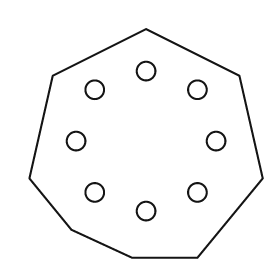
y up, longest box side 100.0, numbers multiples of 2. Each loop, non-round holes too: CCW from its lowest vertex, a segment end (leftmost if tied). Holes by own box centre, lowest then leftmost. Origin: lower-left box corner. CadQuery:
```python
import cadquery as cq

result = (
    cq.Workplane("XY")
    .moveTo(44.0, 0.0)
    .lineTo(72.0, 0.0)
    .lineTo(100.0, 34.0)
    .lineTo(90.0, 78.0)
    .lineTo(50.0, 98.0)
    .lineTo(10.0, 78.0)
    .lineTo(0.0, 34.0)
    .lineTo(18.0, 12.0)
    .close()
    .moveTo(50.0, 20.0)
    .circle(4.0)
    .moveTo(28.0, 28.0)
    .circle(4.0)
    .moveTo(72.0, 28.0)
    .circle(4.0)
    .moveTo(20.0, 50.0)
    .circle(4.0)
    .moveTo(80.0, 50.0)
    .circle(4.0)
    .moveTo(28.0, 72.0)
    .circle(4.0)
    .moveTo(72.0, 72.0)
    .circle(4.0)
    .moveTo(50.0, 80.0)
    .circle(4.0)
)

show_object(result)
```